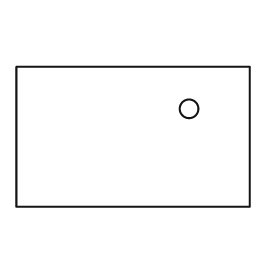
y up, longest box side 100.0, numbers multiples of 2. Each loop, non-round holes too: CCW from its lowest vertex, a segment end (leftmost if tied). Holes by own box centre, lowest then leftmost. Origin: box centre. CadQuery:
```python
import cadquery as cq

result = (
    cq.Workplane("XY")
    .moveTo(-50.0, -30.0)
    .lineTo(50.0, -30.0)
    .lineTo(50.0, 30.0)
    .lineTo(-50.0, 30.0)
    .close()
    .moveTo(24.0, 12.0)
    .circle(4.0)
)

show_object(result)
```